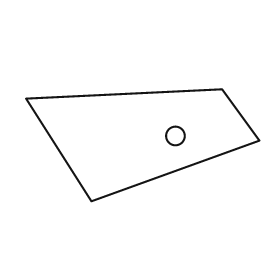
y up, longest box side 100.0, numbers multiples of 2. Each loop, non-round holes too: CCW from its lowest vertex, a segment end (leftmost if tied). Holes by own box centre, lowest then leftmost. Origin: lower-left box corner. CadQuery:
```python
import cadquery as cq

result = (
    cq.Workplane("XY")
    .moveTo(28.0, 0.0)
    .lineTo(100.0, 26.0)
    .lineTo(84.0, 48.0)
    .lineTo(0.0, 44.0)
    .close()
    .moveTo(64.0, 28.0)
    .circle(4.0)
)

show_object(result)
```